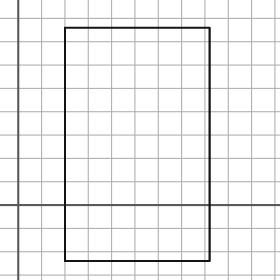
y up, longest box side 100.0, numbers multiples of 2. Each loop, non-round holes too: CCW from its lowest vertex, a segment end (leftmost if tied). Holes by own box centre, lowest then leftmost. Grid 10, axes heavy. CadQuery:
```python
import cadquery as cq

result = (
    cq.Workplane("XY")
    .moveTo(20.0, -24.0)
    .lineTo(82.0, -24.0)
    .lineTo(82.0, 76.0)
    .lineTo(20.0, 76.0)
    .close()
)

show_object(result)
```